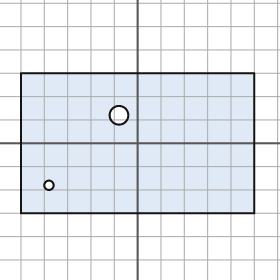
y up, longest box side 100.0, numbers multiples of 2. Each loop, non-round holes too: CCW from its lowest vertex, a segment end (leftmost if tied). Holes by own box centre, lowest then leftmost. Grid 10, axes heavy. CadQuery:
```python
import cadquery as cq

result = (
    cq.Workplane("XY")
    .moveTo(-50.0, -30.0)
    .lineTo(50.0, -30.0)
    .lineTo(50.0, 30.0)
    .lineTo(-50.0, 30.0)
    .close()
    .moveTo(-38.0, -18.0)
    .circle(2.0)
    .moveTo(-8.0, 12.0)
    .circle(4.0)
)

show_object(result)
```